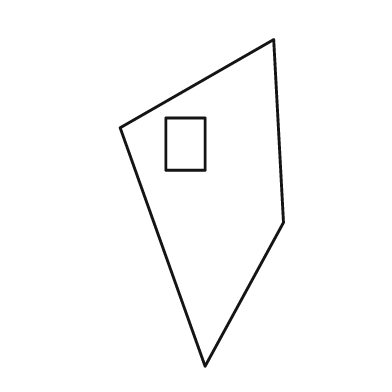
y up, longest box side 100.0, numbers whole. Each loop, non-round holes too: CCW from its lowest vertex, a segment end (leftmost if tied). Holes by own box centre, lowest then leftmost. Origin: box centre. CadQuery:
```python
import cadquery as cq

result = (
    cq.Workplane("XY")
    .moveTo(1.0, -50.0)
    .lineTo(25.0, -6.0)
    .lineTo(22.0, 50.0)
    .lineTo(-25.0, 23.0)
    .close()
    .moveTo(-11.0, 10.0)
    .lineTo(1.0, 10.0)
    .lineTo(1.0, 26.0)
    .lineTo(-11.0, 26.0)
    .close()
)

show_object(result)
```